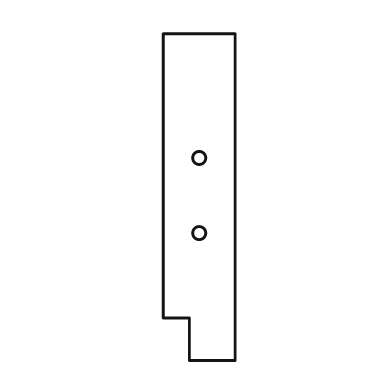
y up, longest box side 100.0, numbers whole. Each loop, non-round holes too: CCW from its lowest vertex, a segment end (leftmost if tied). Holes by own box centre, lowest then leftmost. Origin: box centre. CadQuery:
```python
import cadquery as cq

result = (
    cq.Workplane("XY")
    .moveTo(-3.0, -50.0)
    .lineTo(11.0, -50.0)
    .lineTo(11.0, 50.0)
    .lineTo(-11.0, 50.0)
    .lineTo(-11.0, -37.0)
    .lineTo(-3.0, -37.0)
    .close()
    .moveTo(0.0, -11.0)
    .circle(2.0)
    .moveTo(0.0, 12.0)
    .circle(2.0)
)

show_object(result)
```